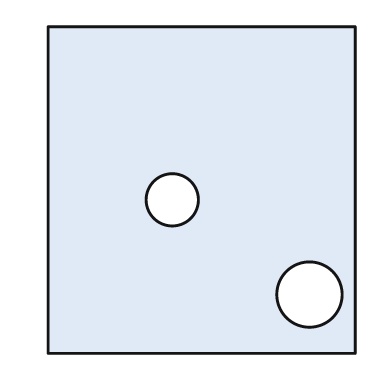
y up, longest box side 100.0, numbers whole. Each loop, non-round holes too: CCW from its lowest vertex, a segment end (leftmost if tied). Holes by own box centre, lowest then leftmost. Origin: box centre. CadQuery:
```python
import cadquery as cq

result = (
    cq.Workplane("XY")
    .moveTo(-47.0, -50.0)
    .lineTo(47.0, -50.0)
    .lineTo(47.0, 50.0)
    .lineTo(-47.0, 50.0)
    .close()
    .moveTo(33.0, -32.0)
    .circle(10.0)
    .moveTo(-9.0, -3.0)
    .circle(8.0)
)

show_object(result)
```